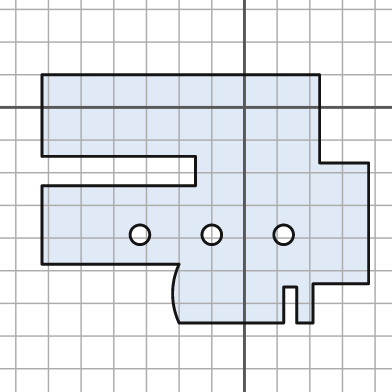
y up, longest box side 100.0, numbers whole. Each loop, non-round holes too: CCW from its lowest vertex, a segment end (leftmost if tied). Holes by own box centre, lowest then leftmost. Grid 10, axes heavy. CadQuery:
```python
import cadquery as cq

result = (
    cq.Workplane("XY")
    .moveTo(-20.0, -66.0)
    .lineTo(12.0, -66.0)
    .lineTo(12.0, -55.0)
    .lineTo(16.0, -55.0)
    .lineTo(16.0, -66.0)
    .lineTo(21.0, -66.0)
    .lineTo(21.0, -54.0)
    .lineTo(38.0, -54.0)
    .lineTo(38.0, -17.0)
    .lineTo(23.0, -17.0)
    .lineTo(23.0, 10.0)
    .lineTo(-62.0, 10.0)
    .lineTo(-62.0, -15.0)
    .lineTo(-15.0, -15.0)
    .lineTo(-15.0, -24.0)
    .lineTo(-62.0, -24.0)
    .lineTo(-62.0, -48.0)
    .lineTo(-20.0, -48.0)
    .threePointArc((-22.0, -57.0), (-20.0, -66.0))
    .close()
    .moveTo(-32.0, -39.0)
    .circle(3.0)
    .moveTo(-10.0, -39.0)
    .circle(3.0)
    .moveTo(12.0, -39.0)
    .circle(3.0)
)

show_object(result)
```